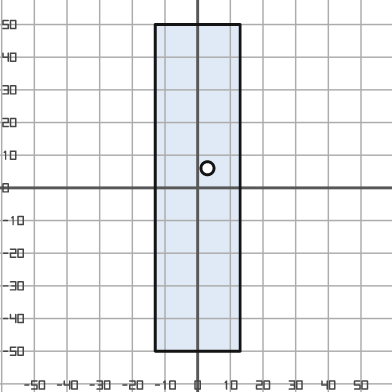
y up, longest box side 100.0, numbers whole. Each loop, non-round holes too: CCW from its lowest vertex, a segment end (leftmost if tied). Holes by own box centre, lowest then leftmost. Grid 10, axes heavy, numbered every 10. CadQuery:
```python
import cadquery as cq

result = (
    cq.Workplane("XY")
    .moveTo(-13.0, -50.0)
    .lineTo(13.0, -50.0)
    .lineTo(13.0, 50.0)
    .lineTo(-13.0, 50.0)
    .close()
    .moveTo(3.0, 6.0)
    .circle(2.0)
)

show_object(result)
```